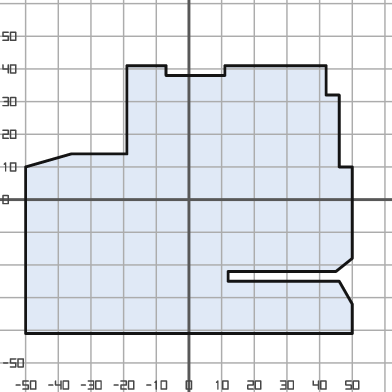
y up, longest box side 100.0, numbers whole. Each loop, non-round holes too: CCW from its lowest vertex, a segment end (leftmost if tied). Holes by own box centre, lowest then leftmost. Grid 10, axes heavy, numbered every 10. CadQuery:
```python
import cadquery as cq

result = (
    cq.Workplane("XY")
    .moveTo(-50.0, -41.0)
    .lineTo(50.0, -41.0)
    .lineTo(50.0, -32.0)
    .lineTo(46.0, -25.0)
    .lineTo(12.0, -25.0)
    .lineTo(12.0, -22.0)
    .lineTo(45.0, -22.0)
    .lineTo(50.0, -18.0)
    .lineTo(50.0, 10.0)
    .lineTo(46.0, 10.0)
    .lineTo(46.0, 32.0)
    .lineTo(42.0, 32.0)
    .lineTo(42.0, 41.0)
    .lineTo(11.0, 41.0)
    .lineTo(11.0, 38.0)
    .lineTo(-7.0, 38.0)
    .lineTo(-7.0, 41.0)
    .lineTo(-19.0, 41.0)
    .lineTo(-19.0, 14.0)
    .lineTo(-36.0, 14.0)
    .lineTo(-50.0, 10.0)
    .close()
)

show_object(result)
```